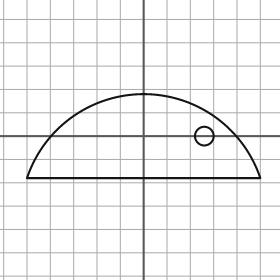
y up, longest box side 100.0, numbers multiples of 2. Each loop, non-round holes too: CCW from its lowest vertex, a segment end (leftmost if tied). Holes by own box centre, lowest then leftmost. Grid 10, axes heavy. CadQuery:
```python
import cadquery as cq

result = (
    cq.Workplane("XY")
    .moveTo(-50.0, -18.0)
    .lineTo(50.0, -18.0)
    .threePointArc((0.0, 18.0), (-50.0, -18.0))
    .close()
    .moveTo(26.0, 0.0)
    .circle(4.0)
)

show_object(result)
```